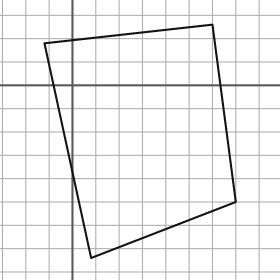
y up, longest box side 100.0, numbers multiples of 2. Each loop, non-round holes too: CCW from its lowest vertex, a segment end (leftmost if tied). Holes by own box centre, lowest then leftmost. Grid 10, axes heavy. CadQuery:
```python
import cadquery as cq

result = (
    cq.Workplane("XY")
    .moveTo(8.0, -74.0)
    .lineTo(70.0, -50.0)
    .lineTo(60.0, 26.0)
    .lineTo(-12.0, 18.0)
    .close()
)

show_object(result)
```